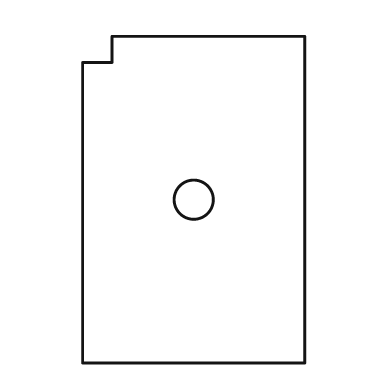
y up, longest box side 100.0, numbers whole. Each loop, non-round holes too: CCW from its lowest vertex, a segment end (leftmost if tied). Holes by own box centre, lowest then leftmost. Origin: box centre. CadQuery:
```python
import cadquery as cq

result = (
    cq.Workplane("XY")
    .moveTo(-34.0, -50.0)
    .lineTo(34.0, -50.0)
    .lineTo(34.0, 50.0)
    .lineTo(-25.0, 50.0)
    .lineTo(-25.0, 42.0)
    .lineTo(-34.0, 42.0)
    .close()
    .moveTo(0.0, 0.0)
    .circle(6.0)
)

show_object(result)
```